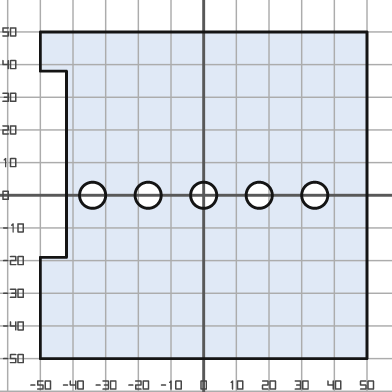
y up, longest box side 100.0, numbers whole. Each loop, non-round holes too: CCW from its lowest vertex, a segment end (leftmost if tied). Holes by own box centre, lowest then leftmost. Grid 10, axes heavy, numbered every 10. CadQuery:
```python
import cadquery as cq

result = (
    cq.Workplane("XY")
    .moveTo(-50.0, -50.0)
    .lineTo(50.0, -50.0)
    .lineTo(50.0, 50.0)
    .lineTo(-50.0, 50.0)
    .lineTo(-50.0, 38.0)
    .lineTo(-42.0, 38.0)
    .lineTo(-42.0, -19.0)
    .lineTo(-50.0, -19.0)
    .close()
    .moveTo(-34.0, 0.0)
    .circle(4.0)
    .moveTo(-17.0, 0.0)
    .circle(4.0)
    .moveTo(0.0, 0.0)
    .circle(4.0)
    .moveTo(17.0, 0.0)
    .circle(4.0)
    .moveTo(34.0, 0.0)
    .circle(4.0)
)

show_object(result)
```